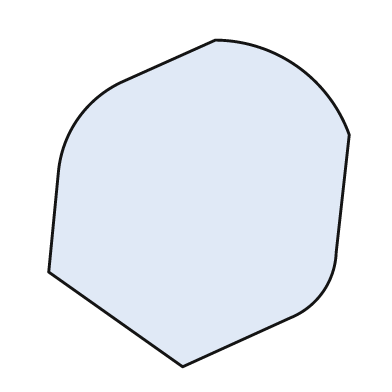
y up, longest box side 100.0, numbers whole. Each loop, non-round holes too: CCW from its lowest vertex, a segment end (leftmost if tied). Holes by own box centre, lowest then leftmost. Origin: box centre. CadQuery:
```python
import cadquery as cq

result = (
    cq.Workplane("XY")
    .moveTo(-5.0, -50.0)
    .lineTo(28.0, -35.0)
    .threePointArc((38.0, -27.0), (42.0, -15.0))
    .lineTo(46.0, 21.0)
    .threePointArc((30.0, 42.0), (5.0, 50.0))
    .lineTo(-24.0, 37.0)
    .threePointArc((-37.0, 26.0), (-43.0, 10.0))
    .lineTo(-46.0, -21.0)
    .close()
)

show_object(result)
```